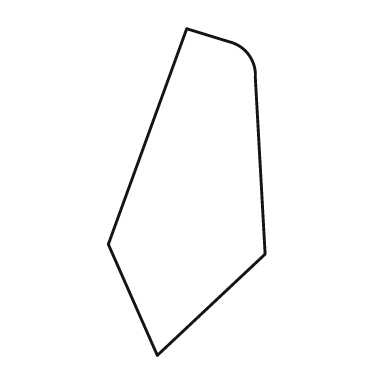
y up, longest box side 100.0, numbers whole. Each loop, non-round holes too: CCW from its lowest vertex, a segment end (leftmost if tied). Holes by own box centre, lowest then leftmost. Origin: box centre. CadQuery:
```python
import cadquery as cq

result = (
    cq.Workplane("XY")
    .moveTo(-9.0, -50.0)
    .lineTo(24.0, -19.0)
    .lineTo(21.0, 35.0)
    .threePointArc((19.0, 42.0), (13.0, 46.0))
    .lineTo(0.0, 50.0)
    .lineTo(-24.0, -16.0)
    .close()
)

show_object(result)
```